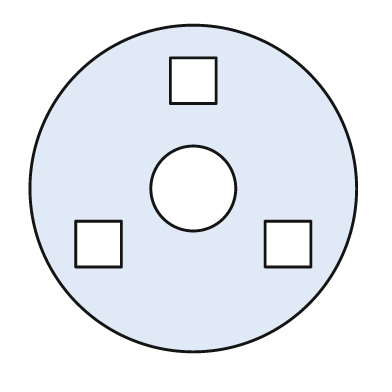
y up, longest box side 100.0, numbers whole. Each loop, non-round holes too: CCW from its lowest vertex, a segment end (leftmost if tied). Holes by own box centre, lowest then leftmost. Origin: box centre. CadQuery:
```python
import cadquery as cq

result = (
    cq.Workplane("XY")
    .moveTo(0.0, 0.0)
    .circle(50.0)
    .moveTo(-36.0, -24.0)
    .lineTo(-22.0, -24.0)
    .lineTo(-22.0, -10.0)
    .lineTo(-36.0, -10.0)
    .close()
    .moveTo(22.0, -24.0)
    .lineTo(36.0, -24.0)
    .lineTo(36.0, -10.0)
    .lineTo(22.0, -10.0)
    .close()
    .moveTo(0.0, 0.0)
    .circle(13.0)
    .moveTo(-7.0, 26.0)
    .lineTo(7.0, 26.0)
    .lineTo(7.0, 40.0)
    .lineTo(-7.0, 40.0)
    .close()
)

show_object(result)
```